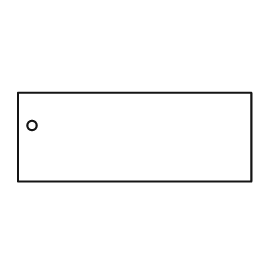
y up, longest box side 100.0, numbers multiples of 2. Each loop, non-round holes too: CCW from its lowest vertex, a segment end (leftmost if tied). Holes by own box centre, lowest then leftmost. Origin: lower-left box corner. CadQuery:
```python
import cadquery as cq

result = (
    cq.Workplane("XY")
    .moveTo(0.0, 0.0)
    .lineTo(100.0, 0.0)
    .lineTo(100.0, 38.0)
    .lineTo(0.0, 38.0)
    .close()
    .moveTo(6.0, 24.0)
    .circle(2.0)
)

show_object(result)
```